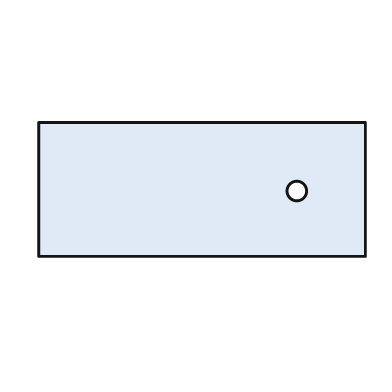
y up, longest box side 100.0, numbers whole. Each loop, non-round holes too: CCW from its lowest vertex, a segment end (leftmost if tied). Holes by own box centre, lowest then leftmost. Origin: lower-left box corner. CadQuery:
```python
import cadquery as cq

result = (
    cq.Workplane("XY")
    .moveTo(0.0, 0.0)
    .lineTo(100.0, 0.0)
    .lineTo(100.0, 41.0)
    .lineTo(0.0, 41.0)
    .close()
    .moveTo(79.0, 20.0)
    .circle(3.0)
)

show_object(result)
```